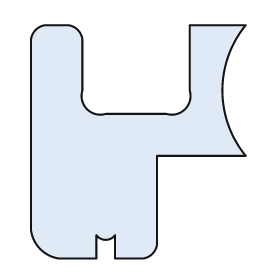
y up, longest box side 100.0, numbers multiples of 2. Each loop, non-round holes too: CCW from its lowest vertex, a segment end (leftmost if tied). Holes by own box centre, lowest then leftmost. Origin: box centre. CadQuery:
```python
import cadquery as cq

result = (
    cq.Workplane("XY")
    .moveTo(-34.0, -50.0)
    .lineTo(-18.0, -50.0)
    .lineTo(-18.0, -40.0)
    .threePointArc((-14.0, -42.0), (-10.0, -40.0))
    .lineTo(-10.0, -50.0)
    .lineTo(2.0, -50.0)
    .threePointArc((6.0, -48.0), (8.0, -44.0))
    .lineTo(8.0, -6.0)
    .lineTo(46.0, -6.0)
    .threePointArc((36.0, 22.0), (46.0, 50.0))
    .lineTo(22.0, 50.0)
    .lineTo(22.0, 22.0)
    .threePointArc((20.0, 14.0), (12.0, 12.0))
    .lineTo(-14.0, 12.0)
    .threePointArc((-22.0, 14.0), (-24.0, 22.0))
    .lineTo(-24.0, 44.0)
    .threePointArc((-26.0, 48.0), (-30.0, 50.0))
    .lineTo(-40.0, 50.0)
    .threePointArc((-44.0, 48.0), (-46.0, 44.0))
    .lineTo(-46.0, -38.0)
    .threePointArc((-42.0, -46.0), (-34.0, -50.0))
    .close()
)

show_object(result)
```